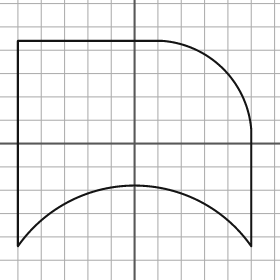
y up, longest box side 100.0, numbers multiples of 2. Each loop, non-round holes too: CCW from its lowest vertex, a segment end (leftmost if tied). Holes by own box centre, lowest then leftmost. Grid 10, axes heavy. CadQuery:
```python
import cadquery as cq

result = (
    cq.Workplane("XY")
    .moveTo(-50.0, -44.0)
    .threePointArc((0.0, -18.0), (50.0, -44.0))
    .lineTo(50.0, 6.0)
    .threePointArc((38.0, 32.0), (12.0, 44.0))
    .lineTo(-50.0, 44.0)
    .close()
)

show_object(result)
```